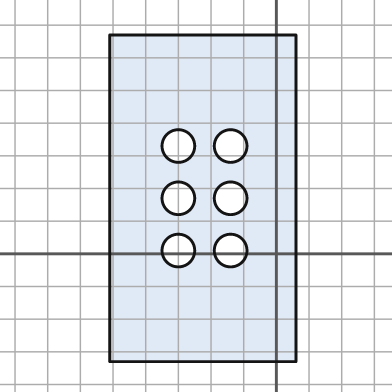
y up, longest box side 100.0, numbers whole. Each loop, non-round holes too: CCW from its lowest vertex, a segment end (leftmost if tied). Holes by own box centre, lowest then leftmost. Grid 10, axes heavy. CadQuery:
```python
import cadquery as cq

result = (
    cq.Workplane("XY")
    .moveTo(-51.0, -33.0)
    .lineTo(6.0, -33.0)
    .lineTo(6.0, 67.0)
    .lineTo(-51.0, 67.0)
    .close()
    .moveTo(-30.0, 1.0)
    .circle(5.0)
    .moveTo(-14.0, 1.0)
    .circle(5.0)
    .moveTo(-30.0, 17.0)
    .circle(5.0)
    .moveTo(-14.0, 17.0)
    .circle(5.0)
    .moveTo(-30.0, 33.0)
    .circle(5.0)
    .moveTo(-14.0, 33.0)
    .circle(5.0)
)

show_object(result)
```